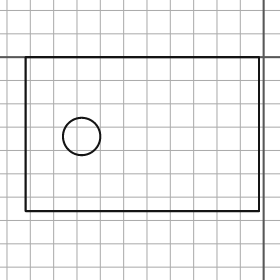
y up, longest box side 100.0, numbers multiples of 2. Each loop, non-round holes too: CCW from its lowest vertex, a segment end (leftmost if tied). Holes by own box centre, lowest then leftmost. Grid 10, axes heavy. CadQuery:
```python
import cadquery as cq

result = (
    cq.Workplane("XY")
    .moveTo(-102.0, -66.0)
    .lineTo(-2.0, -66.0)
    .lineTo(-2.0, 0.0)
    .lineTo(-102.0, 0.0)
    .close()
    .moveTo(-78.0, -34.0)
    .circle(8.0)
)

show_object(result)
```